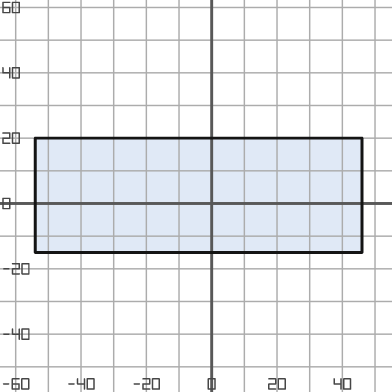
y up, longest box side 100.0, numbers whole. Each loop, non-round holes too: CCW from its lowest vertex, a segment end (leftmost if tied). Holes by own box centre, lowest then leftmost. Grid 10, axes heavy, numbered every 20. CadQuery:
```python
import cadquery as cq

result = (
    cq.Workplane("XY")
    .moveTo(-54.0, -15.0)
    .lineTo(46.0, -15.0)
    .lineTo(46.0, 20.0)
    .lineTo(-54.0, 20.0)
    .close()
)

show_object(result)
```